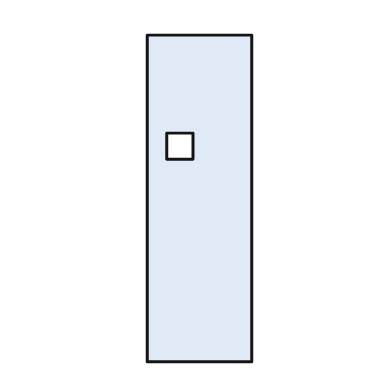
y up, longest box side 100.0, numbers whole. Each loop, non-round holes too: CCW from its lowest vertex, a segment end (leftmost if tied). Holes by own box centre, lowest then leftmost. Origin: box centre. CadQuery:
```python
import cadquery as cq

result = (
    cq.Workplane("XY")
    .moveTo(-16.0, -50.0)
    .lineTo(16.0, -50.0)
    .lineTo(16.0, 50.0)
    .lineTo(-16.0, 50.0)
    .close()
    .moveTo(-10.0, 12.0)
    .lineTo(-2.0, 12.0)
    .lineTo(-2.0, 20.0)
    .lineTo(-10.0, 20.0)
    .close()
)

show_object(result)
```